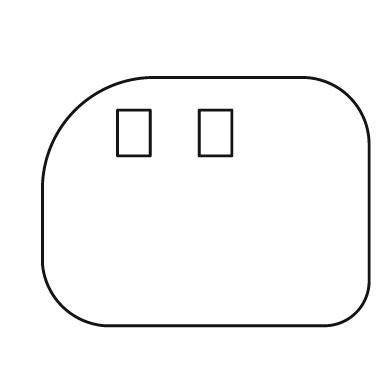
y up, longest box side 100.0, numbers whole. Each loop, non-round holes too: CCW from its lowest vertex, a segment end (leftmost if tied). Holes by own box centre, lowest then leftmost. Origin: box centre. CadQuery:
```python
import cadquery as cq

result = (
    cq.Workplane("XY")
    .moveTo(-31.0, -38.0)
    .lineTo(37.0, -38.0)
    .threePointArc((46.0, -34.0), (50.0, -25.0))
    .lineTo(50.0, 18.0)
    .threePointArc((44.0, 32.0), (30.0, 38.0))
    .lineTo(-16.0, 38.0)
    .threePointArc((-40.0, 28.0), (-50.0, 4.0))
    .lineTo(-50.0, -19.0)
    .threePointArc((-44.0, -32.0), (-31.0, -38.0))
    .close()
    .moveTo(-27.0, 14.0)
    .lineTo(-17.0, 14.0)
    .lineTo(-17.0, 28.0)
    .lineTo(-27.0, 28.0)
    .close()
    .moveTo(-2.0, 14.0)
    .lineTo(8.0, 14.0)
    .lineTo(8.0, 28.0)
    .lineTo(-2.0, 28.0)
    .close()
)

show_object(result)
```